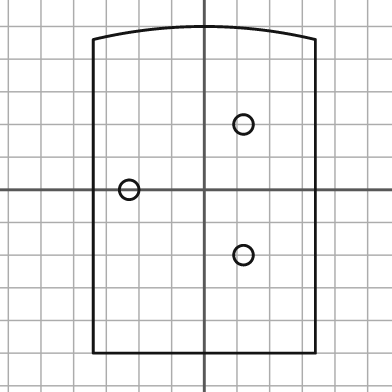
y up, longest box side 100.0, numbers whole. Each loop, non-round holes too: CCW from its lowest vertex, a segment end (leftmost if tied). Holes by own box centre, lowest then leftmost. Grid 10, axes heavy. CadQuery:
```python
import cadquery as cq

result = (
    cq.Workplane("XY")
    .moveTo(-34.0, -50.0)
    .lineTo(34.0, -50.0)
    .lineTo(34.0, 46.0)
    .threePointArc((0.0, 50.0), (-34.0, 46.0))
    .close()
    .moveTo(12.0, -20.0)
    .circle(3.0)
    .moveTo(-23.0, 0.0)
    .circle(3.0)
    .moveTo(12.0, 20.0)
    .circle(3.0)
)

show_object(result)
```